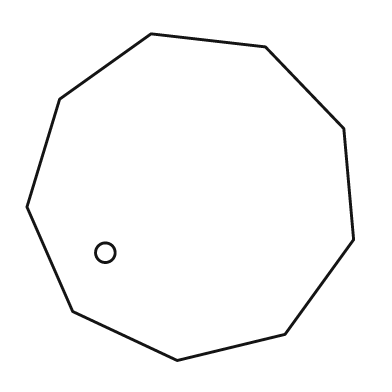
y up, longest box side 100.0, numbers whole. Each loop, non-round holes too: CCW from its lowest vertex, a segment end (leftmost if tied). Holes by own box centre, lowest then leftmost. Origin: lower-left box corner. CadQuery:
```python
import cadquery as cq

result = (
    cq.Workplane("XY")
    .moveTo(46.0, 0.0)
    .lineTo(79.0, 8.0)
    .lineTo(100.0, 37.0)
    .lineTo(97.0, 71.0)
    .lineTo(73.0, 96.0)
    .lineTo(38.0, 100.0)
    .lineTo(10.0, 80.0)
    .lineTo(0.0, 47.0)
    .lineTo(14.0, 15.0)
    .close()
    .moveTo(24.0, 33.0)
    .circle(3.0)
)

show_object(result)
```